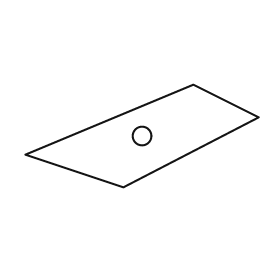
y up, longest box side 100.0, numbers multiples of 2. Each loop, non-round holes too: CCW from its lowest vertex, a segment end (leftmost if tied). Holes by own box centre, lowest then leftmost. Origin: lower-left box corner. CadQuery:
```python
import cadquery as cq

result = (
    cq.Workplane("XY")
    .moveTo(42.0, 0.0)
    .lineTo(100.0, 30.0)
    .lineTo(72.0, 44.0)
    .lineTo(0.0, 14.0)
    .close()
    .moveTo(50.0, 22.0)
    .circle(4.0)
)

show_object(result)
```